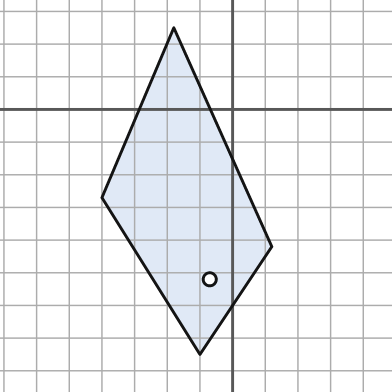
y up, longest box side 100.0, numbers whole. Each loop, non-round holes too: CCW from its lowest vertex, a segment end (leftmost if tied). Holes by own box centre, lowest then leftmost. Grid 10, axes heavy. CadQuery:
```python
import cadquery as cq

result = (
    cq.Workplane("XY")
    .moveTo(-10.0, -75.0)
    .lineTo(12.0, -42.0)
    .lineTo(-18.0, 25.0)
    .lineTo(-40.0, -27.0)
    .close()
    .moveTo(-7.0, -52.0)
    .circle(2.0)
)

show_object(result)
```